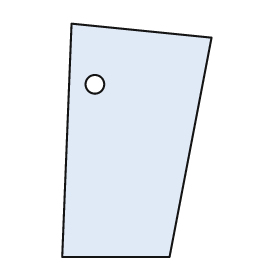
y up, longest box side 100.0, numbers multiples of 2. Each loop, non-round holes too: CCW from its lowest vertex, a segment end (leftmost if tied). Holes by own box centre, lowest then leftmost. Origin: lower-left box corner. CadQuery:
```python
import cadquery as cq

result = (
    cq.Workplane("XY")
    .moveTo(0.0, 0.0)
    .lineTo(46.0, 0.0)
    .lineTo(64.0, 94.0)
    .lineTo(4.0, 100.0)
    .close()
    .moveTo(14.0, 74.0)
    .circle(4.0)
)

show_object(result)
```